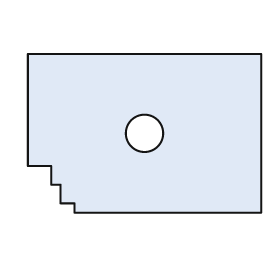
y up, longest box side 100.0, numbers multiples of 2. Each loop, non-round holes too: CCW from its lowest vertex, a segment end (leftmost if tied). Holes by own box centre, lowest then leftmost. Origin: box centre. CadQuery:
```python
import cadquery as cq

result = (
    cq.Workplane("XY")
    .moveTo(-30.0, -34.0)
    .lineTo(50.0, -34.0)
    .lineTo(50.0, 34.0)
    .lineTo(-50.0, 34.0)
    .lineTo(-50.0, -14.0)
    .lineTo(-40.0, -14.0)
    .lineTo(-40.0, -22.0)
    .lineTo(-36.0, -22.0)
    .lineTo(-36.0, -30.0)
    .lineTo(-30.0, -30.0)
    .close()
    .moveTo(0.0, 0.0)
    .circle(8.0)
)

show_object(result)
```